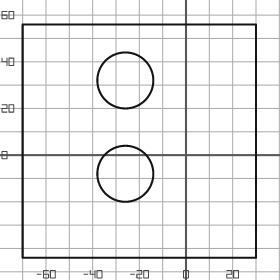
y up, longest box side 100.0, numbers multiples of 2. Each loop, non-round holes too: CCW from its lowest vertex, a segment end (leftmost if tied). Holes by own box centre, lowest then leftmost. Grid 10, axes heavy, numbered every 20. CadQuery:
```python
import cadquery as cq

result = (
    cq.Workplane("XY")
    .moveTo(-70.0, -44.0)
    .lineTo(30.0, -44.0)
    .lineTo(30.0, 56.0)
    .lineTo(-70.0, 56.0)
    .close()
    .moveTo(-26.0, -8.0)
    .circle(12.0)
    .moveTo(-26.0, 32.0)
    .circle(12.0)
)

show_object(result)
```